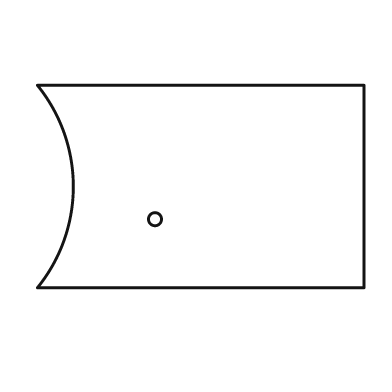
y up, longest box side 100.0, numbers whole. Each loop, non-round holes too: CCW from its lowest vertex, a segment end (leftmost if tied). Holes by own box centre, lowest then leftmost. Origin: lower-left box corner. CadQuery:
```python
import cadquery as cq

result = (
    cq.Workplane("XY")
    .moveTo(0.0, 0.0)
    .lineTo(100.0, 0.0)
    .lineTo(100.0, 62.0)
    .lineTo(0.0, 62.0)
    .threePointArc((11.0, 31.0), (0.0, 0.0))
    .close()
    .moveTo(36.0, 21.0)
    .circle(2.0)
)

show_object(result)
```